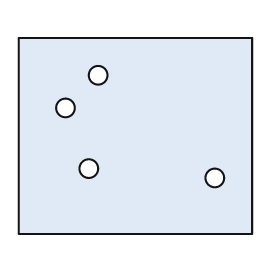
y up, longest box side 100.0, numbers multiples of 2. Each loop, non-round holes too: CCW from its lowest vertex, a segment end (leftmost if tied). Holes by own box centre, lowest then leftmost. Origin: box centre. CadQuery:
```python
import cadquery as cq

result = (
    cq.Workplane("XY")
    .moveTo(-50.0, -42.0)
    .lineTo(50.0, -42.0)
    .lineTo(50.0, 42.0)
    .lineTo(-50.0, 42.0)
    .close()
    .moveTo(34.0, -18.0)
    .circle(4.0)
    .moveTo(-20.0, -14.0)
    .circle(4.0)
    .moveTo(-30.0, 12.0)
    .circle(4.0)
    .moveTo(-16.0, 26.0)
    .circle(4.0)
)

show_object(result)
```